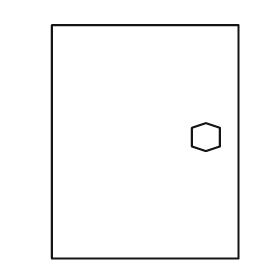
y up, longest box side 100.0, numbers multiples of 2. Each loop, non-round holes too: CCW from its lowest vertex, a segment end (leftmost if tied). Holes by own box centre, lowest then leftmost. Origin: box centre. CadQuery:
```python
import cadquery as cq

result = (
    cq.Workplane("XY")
    .moveTo(-40.0, -50.0)
    .lineTo(40.0, -50.0)
    .lineTo(40.0, 50.0)
    .lineTo(-40.0, 50.0)
    .close()
    .moveTo(26.0, -4.0)
    .lineTo(32.0, -2.0)
    .lineTo(32.0, 6.0)
    .lineTo(26.0, 8.0)
    .lineTo(20.0, 6.0)
    .lineTo(20.0, -2.0)
    .close()
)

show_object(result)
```